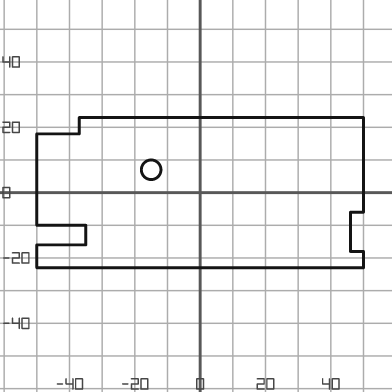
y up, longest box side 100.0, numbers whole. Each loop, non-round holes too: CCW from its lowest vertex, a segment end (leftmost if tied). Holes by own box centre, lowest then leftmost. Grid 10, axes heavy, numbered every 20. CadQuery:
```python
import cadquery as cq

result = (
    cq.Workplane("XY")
    .moveTo(-50.0, -23.0)
    .lineTo(50.0, -23.0)
    .lineTo(50.0, -18.0)
    .lineTo(46.0, -18.0)
    .lineTo(46.0, -6.0)
    .lineTo(50.0, -6.0)
    .lineTo(50.0, 23.0)
    .lineTo(-37.0, 23.0)
    .lineTo(-37.0, 18.0)
    .lineTo(-50.0, 18.0)
    .lineTo(-50.0, -10.0)
    .lineTo(-35.0, -10.0)
    .lineTo(-35.0, -16.0)
    .lineTo(-50.0, -16.0)
    .close()
    .moveTo(-15.0, 7.0)
    .circle(3.0)
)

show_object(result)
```